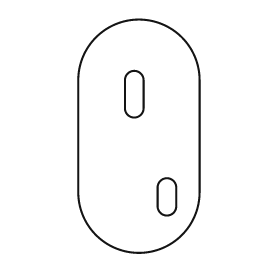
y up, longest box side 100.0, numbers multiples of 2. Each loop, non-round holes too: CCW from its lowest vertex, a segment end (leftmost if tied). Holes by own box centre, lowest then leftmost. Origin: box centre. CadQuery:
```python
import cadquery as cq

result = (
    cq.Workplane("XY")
    .moveTo(-26.0, -24.0)
    .threePointArc((0.0, -50.0), (26.0, -24.0))
    .lineTo(26.0, 24.0)
    .threePointArc((0.0, 50.0), (-26.0, 24.0))
    .close()
    .moveTo(8.0, -30.0)
    .threePointArc((12.0, -34.0), (16.0, -30.0))
    .lineTo(16.0, -22.0)
    .threePointArc((12.0, -18.0), (8.0, -22.0))
    .close()
    .moveTo(-6.0, 12.0)
    .threePointArc((-2.0, 8.0), (2.0, 12.0))
    .lineTo(2.0, 24.0)
    .threePointArc((-2.0, 28.0), (-6.0, 24.0))
    .close()
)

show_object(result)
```